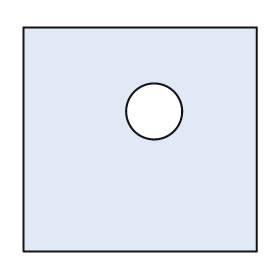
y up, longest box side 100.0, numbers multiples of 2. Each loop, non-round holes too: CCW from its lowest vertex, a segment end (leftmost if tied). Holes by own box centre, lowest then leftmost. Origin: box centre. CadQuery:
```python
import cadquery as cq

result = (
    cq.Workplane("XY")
    .moveTo(-50.0, -48.0)
    .lineTo(50.0, -48.0)
    .lineTo(50.0, 48.0)
    .lineTo(-50.0, 48.0)
    .close()
    .moveTo(6.0, 12.0)
    .circle(12.0)
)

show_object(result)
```